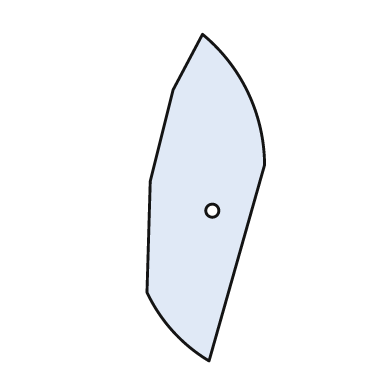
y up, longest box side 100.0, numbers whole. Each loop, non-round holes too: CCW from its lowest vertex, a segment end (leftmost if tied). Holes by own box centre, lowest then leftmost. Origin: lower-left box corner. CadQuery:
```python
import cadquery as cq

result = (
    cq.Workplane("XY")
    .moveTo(19.0, 0.0)
    .lineTo(36.0, 60.0)
    .threePointArc((31.0, 82.0), (17.0, 100.0))
    .lineTo(8.0, 83.0)
    .lineTo(1.0, 55.0)
    .lineTo(0.0, 21.0)
    .threePointArc((8.0, 9.0), (19.0, 0.0))
    .close()
    .moveTo(20.0, 46.0)
    .circle(2.0)
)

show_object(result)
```